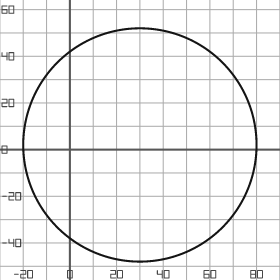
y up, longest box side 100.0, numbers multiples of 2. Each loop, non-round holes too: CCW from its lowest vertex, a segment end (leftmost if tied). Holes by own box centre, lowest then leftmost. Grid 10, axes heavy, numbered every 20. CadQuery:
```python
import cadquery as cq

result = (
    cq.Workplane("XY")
    .moveTo(30.0, 2.0)
    .circle(50.0)
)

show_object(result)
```